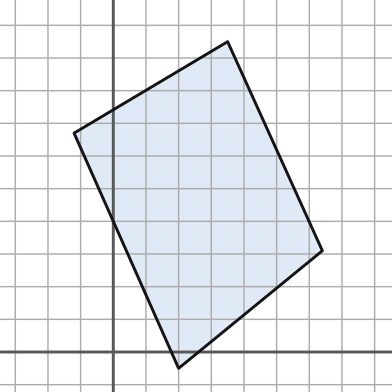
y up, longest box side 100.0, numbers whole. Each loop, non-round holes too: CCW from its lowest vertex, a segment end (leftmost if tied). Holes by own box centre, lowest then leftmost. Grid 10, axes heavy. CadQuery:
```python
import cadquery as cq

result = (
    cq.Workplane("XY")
    .moveTo(20.0, -5.0)
    .lineTo(64.0, 31.0)
    .lineTo(35.0, 95.0)
    .lineTo(-12.0, 67.0)
    .close()
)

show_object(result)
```